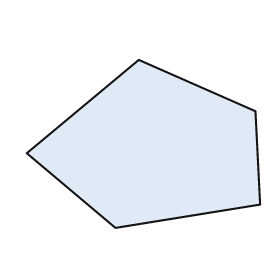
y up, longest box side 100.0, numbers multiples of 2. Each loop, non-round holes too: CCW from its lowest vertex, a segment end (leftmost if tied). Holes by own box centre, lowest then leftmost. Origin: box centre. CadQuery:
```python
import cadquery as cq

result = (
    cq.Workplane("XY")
    .moveTo(-12.0, -36.0)
    .lineTo(50.0, -26.0)
    .lineTo(48.0, 14.0)
    .lineTo(-2.0, 36.0)
    .lineTo(-50.0, -4.0)
    .close()
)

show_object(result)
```